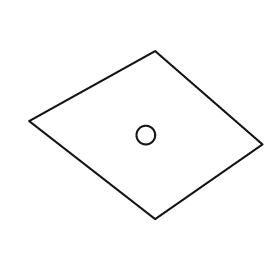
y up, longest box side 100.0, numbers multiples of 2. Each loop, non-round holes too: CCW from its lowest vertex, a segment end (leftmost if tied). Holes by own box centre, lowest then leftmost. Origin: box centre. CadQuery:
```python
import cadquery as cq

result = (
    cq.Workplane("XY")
    .moveTo(4.0, -36.0)
    .lineTo(50.0, -4.0)
    .lineTo(4.0, 36.0)
    .lineTo(-50.0, 6.0)
    .close()
    .moveTo(0.0, 0.0)
    .circle(4.0)
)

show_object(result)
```